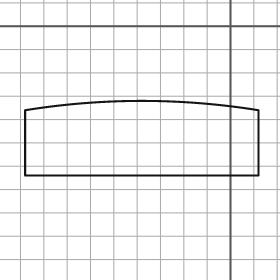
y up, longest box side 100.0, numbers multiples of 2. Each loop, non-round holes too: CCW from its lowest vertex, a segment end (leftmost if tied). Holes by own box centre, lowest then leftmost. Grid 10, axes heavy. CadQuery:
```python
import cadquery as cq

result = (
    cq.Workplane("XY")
    .moveTo(-88.0, -64.0)
    .lineTo(12.0, -64.0)
    .lineTo(12.0, -36.0)
    .threePointArc((-38.0, -32.0), (-88.0, -36.0))
    .close()
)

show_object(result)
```